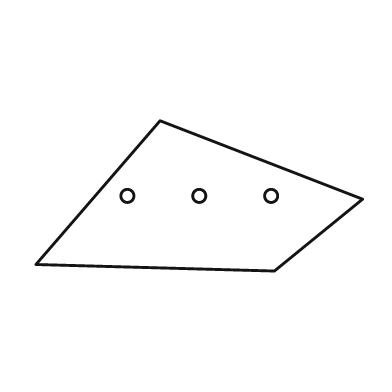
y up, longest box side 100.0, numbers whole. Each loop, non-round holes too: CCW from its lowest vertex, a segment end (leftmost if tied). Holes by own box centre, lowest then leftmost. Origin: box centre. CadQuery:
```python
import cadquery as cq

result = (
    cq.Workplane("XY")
    .moveTo(23.0, -23.0)
    .lineTo(50.0, -1.0)
    .lineTo(-12.0, 23.0)
    .lineTo(-50.0, -21.0)
    .close()
    .moveTo(-22.0, 0.0)
    .circle(2.0)
    .moveTo(0.0, 0.0)
    .circle(2.0)
    .moveTo(22.0, 0.0)
    .circle(2.0)
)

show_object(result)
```